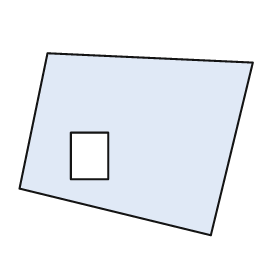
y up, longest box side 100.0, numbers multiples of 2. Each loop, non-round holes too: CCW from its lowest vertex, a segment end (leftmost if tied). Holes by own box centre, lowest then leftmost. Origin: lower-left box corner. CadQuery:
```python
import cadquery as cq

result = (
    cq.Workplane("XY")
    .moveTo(82.0, 0.0)
    .lineTo(100.0, 74.0)
    .lineTo(12.0, 78.0)
    .lineTo(0.0, 20.0)
    .close()
    .moveTo(22.0, 24.0)
    .lineTo(38.0, 24.0)
    .lineTo(38.0, 44.0)
    .lineTo(22.0, 44.0)
    .close()
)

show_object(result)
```